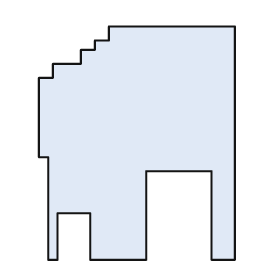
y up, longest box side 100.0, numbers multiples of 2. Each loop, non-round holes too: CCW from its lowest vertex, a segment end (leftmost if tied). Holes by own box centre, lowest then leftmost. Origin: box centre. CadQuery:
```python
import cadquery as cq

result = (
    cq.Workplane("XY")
    .moveTo(-38.0, -50.0)
    .lineTo(-34.0, -50.0)
    .lineTo(-34.0, -30.0)
    .lineTo(-20.0, -30.0)
    .lineTo(-20.0, -50.0)
    .lineTo(4.0, -50.0)
    .lineTo(4.0, -12.0)
    .lineTo(32.0, -12.0)
    .lineTo(32.0, -50.0)
    .lineTo(42.0, -50.0)
    .lineTo(42.0, 50.0)
    .lineTo(-12.0, 50.0)
    .lineTo(-12.0, 44.0)
    .lineTo(-18.0, 44.0)
    .lineTo(-18.0, 40.0)
    .lineTo(-24.0, 40.0)
    .lineTo(-24.0, 34.0)
    .lineTo(-36.0, 34.0)
    .lineTo(-36.0, 28.0)
    .lineTo(-42.0, 28.0)
    .lineTo(-42.0, -6.0)
    .lineTo(-38.0, -6.0)
    .close()
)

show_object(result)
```